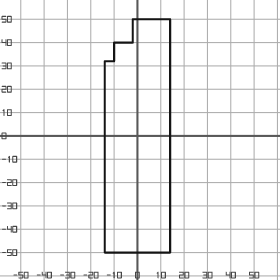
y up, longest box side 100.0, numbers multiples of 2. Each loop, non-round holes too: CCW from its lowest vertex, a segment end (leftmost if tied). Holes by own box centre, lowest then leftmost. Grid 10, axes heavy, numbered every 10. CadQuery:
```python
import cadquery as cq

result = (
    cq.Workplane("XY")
    .moveTo(-14.0, -50.0)
    .lineTo(14.0, -50.0)
    .lineTo(14.0, 50.0)
    .lineTo(-2.0, 50.0)
    .lineTo(-2.0, 40.0)
    .lineTo(-10.0, 40.0)
    .lineTo(-10.0, 32.0)
    .lineTo(-14.0, 32.0)
    .close()
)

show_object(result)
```